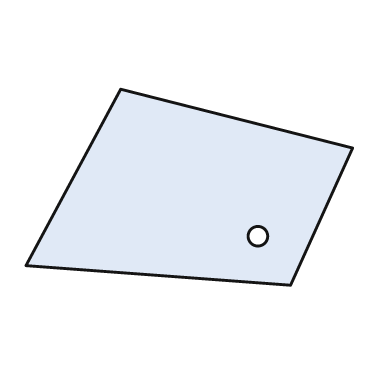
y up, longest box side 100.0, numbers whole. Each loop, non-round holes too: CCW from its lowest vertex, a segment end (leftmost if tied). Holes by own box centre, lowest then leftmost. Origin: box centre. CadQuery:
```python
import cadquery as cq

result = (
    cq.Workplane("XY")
    .moveTo(31.0, -30.0)
    .lineTo(50.0, 12.0)
    .lineTo(-21.0, 30.0)
    .lineTo(-50.0, -24.0)
    .close()
    .moveTo(21.0, -15.0)
    .circle(3.0)
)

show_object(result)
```